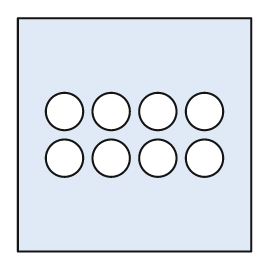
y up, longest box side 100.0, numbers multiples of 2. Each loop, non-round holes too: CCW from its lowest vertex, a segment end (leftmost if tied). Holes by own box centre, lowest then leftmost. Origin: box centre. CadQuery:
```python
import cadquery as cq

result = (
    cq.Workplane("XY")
    .moveTo(-50.0, -50.0)
    .lineTo(50.0, -50.0)
    .lineTo(50.0, 50.0)
    .lineTo(-50.0, 50.0)
    .close()
    .moveTo(-30.0, -10.0)
    .circle(8.0)
    .moveTo(-10.0, -10.0)
    .circle(8.0)
    .moveTo(10.0, -10.0)
    .circle(8.0)
    .moveTo(30.0, -10.0)
    .circle(8.0)
    .moveTo(-30.0, 10.0)
    .circle(8.0)
    .moveTo(-10.0, 10.0)
    .circle(8.0)
    .moveTo(10.0, 10.0)
    .circle(8.0)
    .moveTo(30.0, 10.0)
    .circle(8.0)
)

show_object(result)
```